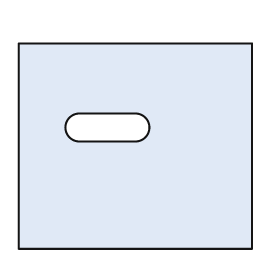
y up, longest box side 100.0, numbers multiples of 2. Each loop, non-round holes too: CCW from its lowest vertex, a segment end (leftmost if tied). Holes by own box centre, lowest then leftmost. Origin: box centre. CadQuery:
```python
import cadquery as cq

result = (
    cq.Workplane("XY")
    .moveTo(-50.0, -44.0)
    .lineTo(50.0, -44.0)
    .lineTo(50.0, 44.0)
    .lineTo(-50.0, 44.0)
    .close()
    .moveTo(-24.0, 2.0)
    .lineTo(0.0, 2.0)
    .threePointArc((6.0, 8.0), (0.0, 14.0))
    .lineTo(-24.0, 14.0)
    .threePointArc((-30.0, 8.0), (-24.0, 2.0))
    .close()
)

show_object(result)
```